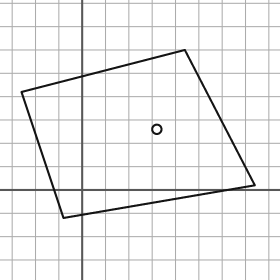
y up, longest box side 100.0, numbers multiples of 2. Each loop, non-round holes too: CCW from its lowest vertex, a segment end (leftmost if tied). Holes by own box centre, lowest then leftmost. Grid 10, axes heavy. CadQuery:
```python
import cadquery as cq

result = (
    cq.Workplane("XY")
    .moveTo(-8.0, -12.0)
    .lineTo(74.0, 2.0)
    .lineTo(44.0, 60.0)
    .lineTo(-26.0, 42.0)
    .close()
    .moveTo(32.0, 26.0)
    .circle(2.0)
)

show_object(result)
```